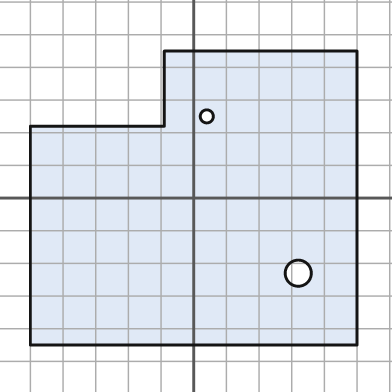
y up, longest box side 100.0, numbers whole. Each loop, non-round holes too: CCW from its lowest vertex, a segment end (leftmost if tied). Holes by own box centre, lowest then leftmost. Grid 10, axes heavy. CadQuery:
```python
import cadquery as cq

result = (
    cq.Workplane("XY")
    .moveTo(-50.0, -45.0)
    .lineTo(50.0, -45.0)
    .lineTo(50.0, 45.0)
    .lineTo(-9.0, 45.0)
    .lineTo(-9.0, 22.0)
    .lineTo(-50.0, 22.0)
    .close()
    .moveTo(32.0, -23.0)
    .circle(4.0)
    .moveTo(4.0, 25.0)
    .circle(2.0)
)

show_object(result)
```